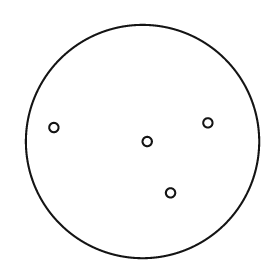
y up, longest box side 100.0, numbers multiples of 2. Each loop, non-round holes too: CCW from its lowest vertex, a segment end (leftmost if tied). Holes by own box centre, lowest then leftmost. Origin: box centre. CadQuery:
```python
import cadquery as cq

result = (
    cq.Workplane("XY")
    .moveTo(0.0, 0.0)
    .circle(50.0)
    .moveTo(12.0, -22.0)
    .circle(2.0)
    .moveTo(2.0, 0.0)
    .circle(2.0)
    .moveTo(-38.0, 6.0)
    .circle(2.0)
    .moveTo(28.0, 8.0)
    .circle(2.0)
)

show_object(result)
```